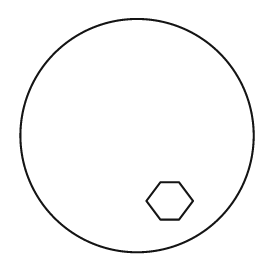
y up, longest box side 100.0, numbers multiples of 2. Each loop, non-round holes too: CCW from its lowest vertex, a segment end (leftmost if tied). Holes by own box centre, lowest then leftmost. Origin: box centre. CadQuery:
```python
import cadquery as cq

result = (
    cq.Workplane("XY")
    .moveTo(0.0, 0.0)
    .circle(50.0)
    .moveTo(10.0, -36.0)
    .lineTo(18.0, -36.0)
    .lineTo(24.0, -28.0)
    .lineTo(18.0, -20.0)
    .lineTo(10.0, -20.0)
    .lineTo(4.0, -28.0)
    .close()
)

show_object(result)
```